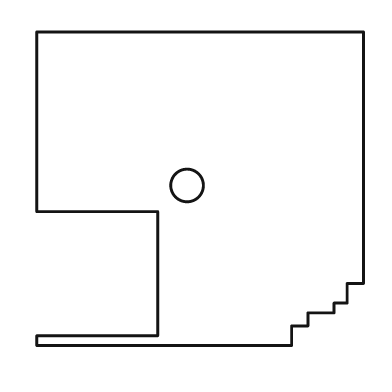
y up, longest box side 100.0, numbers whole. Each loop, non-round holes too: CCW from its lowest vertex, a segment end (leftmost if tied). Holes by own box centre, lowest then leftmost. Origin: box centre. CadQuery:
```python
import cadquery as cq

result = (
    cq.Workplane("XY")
    .moveTo(-50.0, -48.0)
    .lineTo(28.0, -48.0)
    .lineTo(28.0, -42.0)
    .lineTo(33.0, -42.0)
    .lineTo(33.0, -38.0)
    .lineTo(41.0, -38.0)
    .lineTo(41.0, -35.0)
    .lineTo(45.0, -35.0)
    .lineTo(45.0, -29.0)
    .lineTo(50.0, -29.0)
    .lineTo(50.0, 48.0)
    .lineTo(-50.0, 48.0)
    .lineTo(-50.0, -7.0)
    .lineTo(-13.0, -7.0)
    .lineTo(-13.0, -45.0)
    .lineTo(-50.0, -45.0)
    .close()
    .moveTo(-4.0, 1.0)
    .circle(5.0)
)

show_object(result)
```